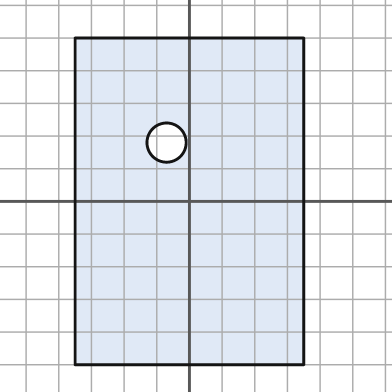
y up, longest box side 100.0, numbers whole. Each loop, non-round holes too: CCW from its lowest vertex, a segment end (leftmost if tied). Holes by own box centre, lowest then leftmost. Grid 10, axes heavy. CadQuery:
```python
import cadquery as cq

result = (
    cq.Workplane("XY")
    .moveTo(-35.0, -50.0)
    .lineTo(35.0, -50.0)
    .lineTo(35.0, 50.0)
    .lineTo(-35.0, 50.0)
    .close()
    .moveTo(-7.0, 18.0)
    .circle(6.0)
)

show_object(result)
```